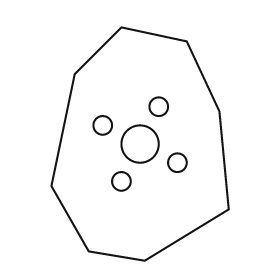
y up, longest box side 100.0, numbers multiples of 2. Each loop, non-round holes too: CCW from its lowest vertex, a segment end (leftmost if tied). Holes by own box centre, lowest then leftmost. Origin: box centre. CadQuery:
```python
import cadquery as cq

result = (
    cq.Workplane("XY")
    .moveTo(2.0, -50.0)
    .lineTo(38.0, -28.0)
    .lineTo(34.0, 14.0)
    .lineTo(20.0, 44.0)
    .lineTo(-8.0, 50.0)
    .lineTo(-28.0, 30.0)
    .lineTo(-38.0, -18.0)
    .lineTo(-22.0, -46.0)
    .close()
    .moveTo(-8.0, -16.0)
    .circle(4.0)
    .moveTo(16.0, -8.0)
    .circle(4.0)
    .moveTo(0.0, 0.0)
    .circle(8.0)
    .moveTo(-16.0, 8.0)
    .circle(4.0)
    .moveTo(8.0, 16.0)
    .circle(4.0)
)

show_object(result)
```